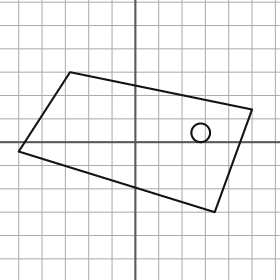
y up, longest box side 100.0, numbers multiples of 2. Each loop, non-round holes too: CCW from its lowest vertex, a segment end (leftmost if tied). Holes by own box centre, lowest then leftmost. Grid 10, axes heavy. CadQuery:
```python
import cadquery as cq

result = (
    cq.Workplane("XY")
    .moveTo(34.0, -30.0)
    .lineTo(50.0, 14.0)
    .lineTo(-28.0, 30.0)
    .lineTo(-50.0, -4.0)
    .close()
    .moveTo(28.0, 4.0)
    .circle(4.0)
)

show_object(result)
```